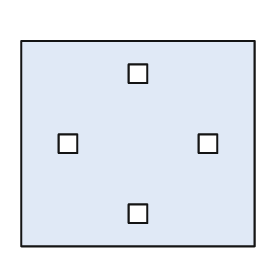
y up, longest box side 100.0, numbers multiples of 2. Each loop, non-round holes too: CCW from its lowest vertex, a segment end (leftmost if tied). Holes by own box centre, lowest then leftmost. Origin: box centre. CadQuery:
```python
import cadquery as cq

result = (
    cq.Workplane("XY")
    .moveTo(-50.0, -44.0)
    .lineTo(50.0, -44.0)
    .lineTo(50.0, 44.0)
    .lineTo(-50.0, 44.0)
    .close()
    .moveTo(-4.0, -34.0)
    .lineTo(4.0, -34.0)
    .lineTo(4.0, -26.0)
    .lineTo(-4.0, -26.0)
    .close()
    .moveTo(-34.0, -4.0)
    .lineTo(-26.0, -4.0)
    .lineTo(-26.0, 4.0)
    .lineTo(-34.0, 4.0)
    .close()
    .moveTo(26.0, -4.0)
    .lineTo(34.0, -4.0)
    .lineTo(34.0, 4.0)
    .lineTo(26.0, 4.0)
    .close()
    .moveTo(-4.0, 26.0)
    .lineTo(4.0, 26.0)
    .lineTo(4.0, 34.0)
    .lineTo(-4.0, 34.0)
    .close()
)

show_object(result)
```